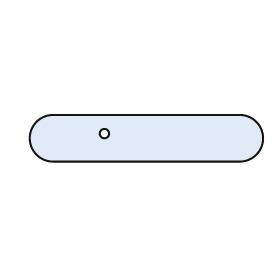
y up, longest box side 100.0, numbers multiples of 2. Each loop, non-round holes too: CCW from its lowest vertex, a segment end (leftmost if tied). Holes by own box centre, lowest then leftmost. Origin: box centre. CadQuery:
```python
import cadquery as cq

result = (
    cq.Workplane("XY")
    .moveTo(-40.0, -10.0)
    .lineTo(40.0, -10.0)
    .threePointArc((50.0, 0.0), (40.0, 10.0))
    .lineTo(-40.0, 10.0)
    .threePointArc((-50.0, 0.0), (-40.0, -10.0))
    .close()
    .moveTo(-18.0, 2.0)
    .circle(2.0)
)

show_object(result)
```